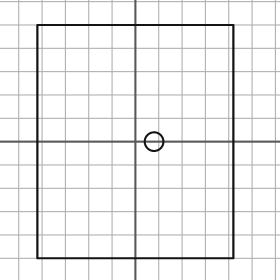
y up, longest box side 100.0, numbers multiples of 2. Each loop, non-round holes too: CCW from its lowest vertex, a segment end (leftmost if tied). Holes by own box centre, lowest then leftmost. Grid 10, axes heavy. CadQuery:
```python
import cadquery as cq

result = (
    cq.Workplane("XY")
    .moveTo(-42.0, -50.0)
    .lineTo(42.0, -50.0)
    .lineTo(42.0, 50.0)
    .lineTo(-42.0, 50.0)
    .close()
    .moveTo(8.0, 0.0)
    .circle(4.0)
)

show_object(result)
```